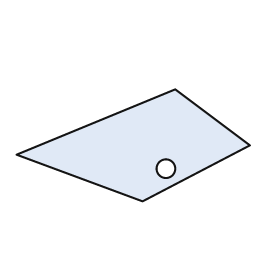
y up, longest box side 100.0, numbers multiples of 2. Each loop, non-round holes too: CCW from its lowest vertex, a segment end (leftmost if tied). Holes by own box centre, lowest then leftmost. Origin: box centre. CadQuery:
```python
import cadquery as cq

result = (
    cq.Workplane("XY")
    .moveTo(4.0, -24.0)
    .lineTo(50.0, 0.0)
    .lineTo(18.0, 24.0)
    .lineTo(-50.0, -4.0)
    .close()
    .moveTo(14.0, -10.0)
    .circle(4.0)
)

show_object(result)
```